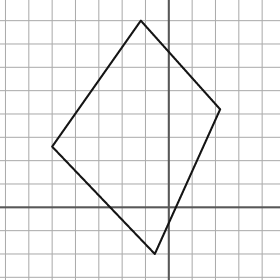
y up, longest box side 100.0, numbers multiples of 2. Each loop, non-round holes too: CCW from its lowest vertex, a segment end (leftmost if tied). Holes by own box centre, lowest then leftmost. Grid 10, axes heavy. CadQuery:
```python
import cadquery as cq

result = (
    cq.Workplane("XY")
    .moveTo(-6.0, -20.0)
    .lineTo(22.0, 42.0)
    .lineTo(-12.0, 80.0)
    .lineTo(-50.0, 26.0)
    .close()
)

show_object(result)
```